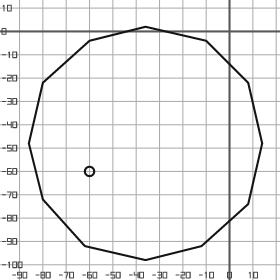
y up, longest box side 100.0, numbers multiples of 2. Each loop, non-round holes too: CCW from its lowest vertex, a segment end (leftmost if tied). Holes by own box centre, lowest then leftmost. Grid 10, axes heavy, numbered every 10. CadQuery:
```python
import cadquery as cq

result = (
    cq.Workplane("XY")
    .moveTo(-36.0, -98.0)
    .lineTo(-12.0, -92.0)
    .lineTo(8.0, -74.0)
    .lineTo(14.0, -48.0)
    .lineTo(8.0, -22.0)
    .lineTo(-10.0, -4.0)
    .lineTo(-36.0, 2.0)
    .lineTo(-60.0, -4.0)
    .lineTo(-80.0, -22.0)
    .lineTo(-86.0, -48.0)
    .lineTo(-80.0, -72.0)
    .lineTo(-62.0, -92.0)
    .close()
    .moveTo(-60.0, -60.0)
    .circle(2.0)
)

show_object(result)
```